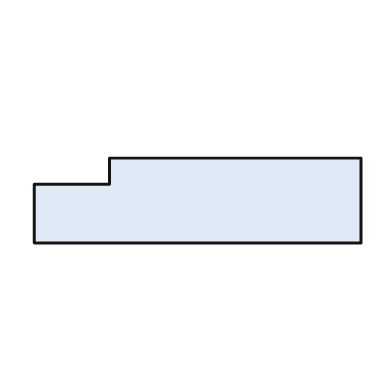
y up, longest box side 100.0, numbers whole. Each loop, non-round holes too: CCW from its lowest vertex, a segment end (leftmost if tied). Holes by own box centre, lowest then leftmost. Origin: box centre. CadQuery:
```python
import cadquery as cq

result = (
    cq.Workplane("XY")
    .moveTo(-50.0, -13.0)
    .lineTo(50.0, -13.0)
    .lineTo(50.0, 13.0)
    .lineTo(-27.0, 13.0)
    .lineTo(-27.0, 5.0)
    .lineTo(-50.0, 5.0)
    .close()
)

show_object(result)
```